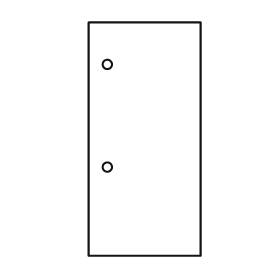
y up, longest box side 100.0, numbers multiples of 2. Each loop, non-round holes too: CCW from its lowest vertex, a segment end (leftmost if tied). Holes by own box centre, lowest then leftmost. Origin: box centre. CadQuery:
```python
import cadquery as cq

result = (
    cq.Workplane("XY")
    .moveTo(-24.0, -50.0)
    .lineTo(24.0, -50.0)
    .lineTo(24.0, 50.0)
    .lineTo(-24.0, 50.0)
    .close()
    .moveTo(-16.0, -12.0)
    .circle(2.0)
    .moveTo(-16.0, 32.0)
    .circle(2.0)
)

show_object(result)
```